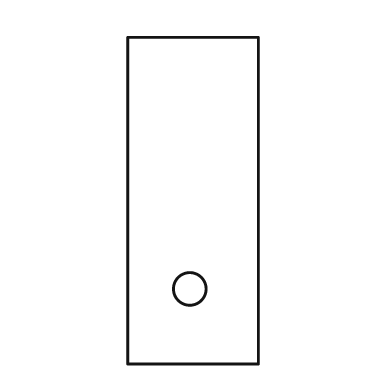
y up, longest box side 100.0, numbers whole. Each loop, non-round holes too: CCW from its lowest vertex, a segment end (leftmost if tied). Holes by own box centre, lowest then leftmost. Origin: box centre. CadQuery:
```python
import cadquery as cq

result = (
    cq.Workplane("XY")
    .moveTo(-20.0, -50.0)
    .lineTo(20.0, -50.0)
    .lineTo(20.0, 50.0)
    .lineTo(-20.0, 50.0)
    .close()
    .moveTo(-1.0, -27.0)
    .circle(5.0)
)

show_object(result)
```